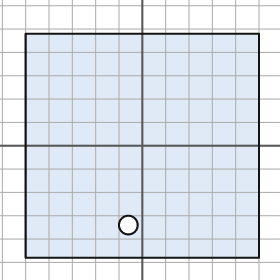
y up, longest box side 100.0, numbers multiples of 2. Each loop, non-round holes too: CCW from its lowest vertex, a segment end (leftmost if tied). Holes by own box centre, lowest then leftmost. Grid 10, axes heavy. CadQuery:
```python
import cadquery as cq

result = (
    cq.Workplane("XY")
    .moveTo(-50.0, -48.0)
    .lineTo(50.0, -48.0)
    .lineTo(50.0, 48.0)
    .lineTo(-50.0, 48.0)
    .close()
    .moveTo(-6.0, -34.0)
    .circle(4.0)
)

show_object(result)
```